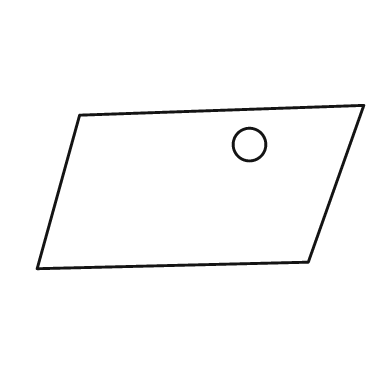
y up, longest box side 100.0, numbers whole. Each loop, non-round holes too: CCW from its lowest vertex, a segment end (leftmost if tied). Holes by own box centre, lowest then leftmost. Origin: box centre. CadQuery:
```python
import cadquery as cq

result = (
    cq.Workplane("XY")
    .moveTo(-50.0, -25.0)
    .lineTo(33.0, -23.0)
    .lineTo(50.0, 25.0)
    .lineTo(-37.0, 22.0)
    .close()
    .moveTo(15.0, 13.0)
    .circle(5.0)
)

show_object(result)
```